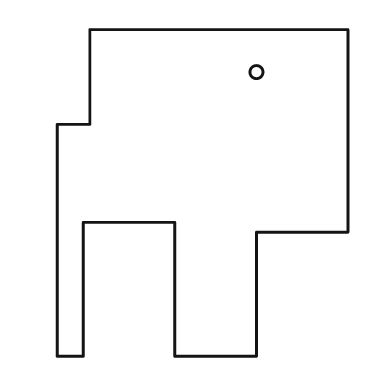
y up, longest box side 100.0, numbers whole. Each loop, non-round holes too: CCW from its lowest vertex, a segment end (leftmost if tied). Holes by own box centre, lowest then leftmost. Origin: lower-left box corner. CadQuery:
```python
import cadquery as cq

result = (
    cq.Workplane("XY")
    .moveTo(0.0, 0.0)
    .lineTo(8.0, 0.0)
    .lineTo(8.0, 41.0)
    .lineTo(36.0, 41.0)
    .lineTo(36.0, 0.0)
    .lineTo(61.0, 0.0)
    .lineTo(61.0, 38.0)
    .lineTo(89.0, 38.0)
    .lineTo(89.0, 100.0)
    .lineTo(10.0, 100.0)
    .lineTo(10.0, 71.0)
    .lineTo(0.0, 71.0)
    .close()
    .moveTo(61.0, 87.0)
    .circle(2.0)
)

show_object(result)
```